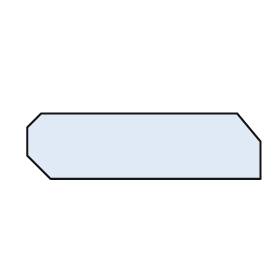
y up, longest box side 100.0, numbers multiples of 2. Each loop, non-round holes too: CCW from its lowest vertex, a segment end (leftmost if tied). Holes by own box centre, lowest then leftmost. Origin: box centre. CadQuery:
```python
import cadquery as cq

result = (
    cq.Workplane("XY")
    .moveTo(-40.0, -14.0)
    .lineTo(50.0, -14.0)
    .lineTo(50.0, 2.0)
    .lineTo(40.0, 14.0)
    .lineTo(-44.0, 14.0)
    .lineTo(-50.0, 8.0)
    .lineTo(-50.0, -4.0)
    .close()
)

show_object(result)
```